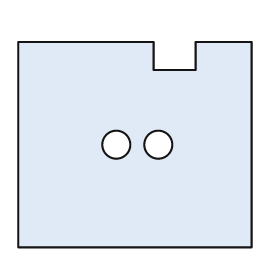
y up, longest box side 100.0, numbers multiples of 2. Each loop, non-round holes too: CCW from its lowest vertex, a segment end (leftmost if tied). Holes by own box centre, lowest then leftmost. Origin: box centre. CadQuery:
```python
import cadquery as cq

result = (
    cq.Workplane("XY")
    .moveTo(-50.0, -44.0)
    .lineTo(50.0, -44.0)
    .lineTo(50.0, 44.0)
    .lineTo(26.0, 44.0)
    .lineTo(26.0, 32.0)
    .lineTo(8.0, 32.0)
    .lineTo(8.0, 44.0)
    .lineTo(-50.0, 44.0)
    .close()
    .moveTo(-8.0, 0.0)
    .circle(6.0)
    .moveTo(10.0, 0.0)
    .circle(6.0)
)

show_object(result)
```